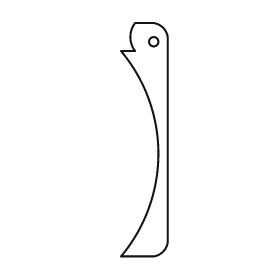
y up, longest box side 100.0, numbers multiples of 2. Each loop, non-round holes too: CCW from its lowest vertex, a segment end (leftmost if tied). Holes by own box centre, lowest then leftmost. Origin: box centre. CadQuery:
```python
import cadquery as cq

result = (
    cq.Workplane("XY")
    .moveTo(-10.0, -50.0)
    .lineTo(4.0, -50.0)
    .threePointArc((8.0, -48.0), (10.0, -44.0))
    .lineTo(10.0, 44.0)
    .threePointArc((8.0, 48.0), (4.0, 50.0))
    .lineTo(-4.0, 50.0)
    .threePointArc((-6.0, 44.0), (-4.0, 38.0))
    .lineTo(-10.0, 38.0)
    .threePointArc((6.0, -6.0), (-10.0, -50.0))
    .close()
    .moveTo(4.0, 42.0)
    .circle(2.0)
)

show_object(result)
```